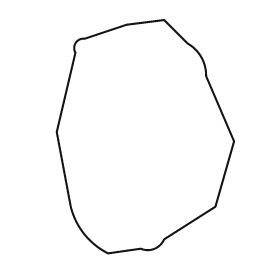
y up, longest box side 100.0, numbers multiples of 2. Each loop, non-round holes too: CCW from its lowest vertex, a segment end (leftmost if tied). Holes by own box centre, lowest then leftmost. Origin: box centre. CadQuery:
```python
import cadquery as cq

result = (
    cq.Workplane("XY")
    .moveTo(-16.0, -50.0)
    .lineTo(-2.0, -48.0)
    .threePointArc((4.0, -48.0), (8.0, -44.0))
    .lineTo(30.0, -30.0)
    .lineTo(38.0, -2.0)
    .lineTo(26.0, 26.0)
    .threePointArc((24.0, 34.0), (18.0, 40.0))
    .lineTo(8.0, 50.0)
    .lineTo(-8.0, 48.0)
    .lineTo(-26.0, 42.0)
    .threePointArc((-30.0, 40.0), (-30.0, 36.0))
    .lineTo(-38.0, 2.0)
    .lineTo(-32.0, -30.0)
    .threePointArc((-26.0, -42.0), (-16.0, -50.0))
    .close()
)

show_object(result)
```